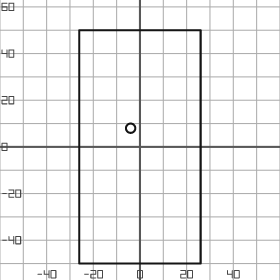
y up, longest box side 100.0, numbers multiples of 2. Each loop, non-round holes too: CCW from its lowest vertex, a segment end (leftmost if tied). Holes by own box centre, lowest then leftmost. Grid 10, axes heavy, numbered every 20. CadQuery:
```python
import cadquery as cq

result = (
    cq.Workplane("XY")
    .moveTo(-26.0, -50.0)
    .lineTo(26.0, -50.0)
    .lineTo(26.0, 50.0)
    .lineTo(-26.0, 50.0)
    .close()
    .moveTo(-4.0, 8.0)
    .circle(2.0)
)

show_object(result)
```